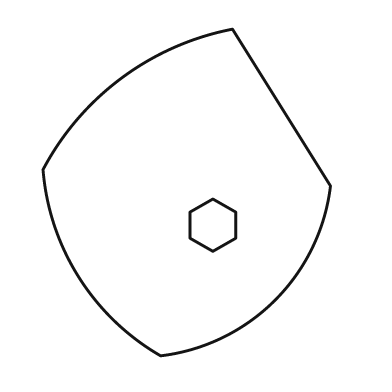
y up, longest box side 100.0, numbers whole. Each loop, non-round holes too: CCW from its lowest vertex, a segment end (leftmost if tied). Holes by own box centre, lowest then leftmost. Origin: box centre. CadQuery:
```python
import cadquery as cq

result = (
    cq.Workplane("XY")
    .moveTo(-8.0, -50.0)
    .threePointArc((27.0, -33.0), (44.0, 2.0))
    .lineTo(14.0, 50.0)
    .threePointArc((-20.0, 35.0), (-44.0, 7.0))
    .threePointArc((-33.0, -26.0), (-8.0, -50.0))
    .close()
    .moveTo(8.0, -18.0)
    .lineTo(15.0, -14.0)
    .lineTo(15.0, -6.0)
    .lineTo(8.0, -2.0)
    .lineTo(1.0, -6.0)
    .lineTo(1.0, -14.0)
    .close()
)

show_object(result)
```